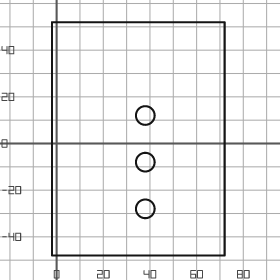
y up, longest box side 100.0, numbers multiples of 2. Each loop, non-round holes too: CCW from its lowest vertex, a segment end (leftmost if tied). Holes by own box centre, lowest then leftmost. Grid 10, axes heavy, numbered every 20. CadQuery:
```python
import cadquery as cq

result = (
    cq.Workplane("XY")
    .moveTo(-2.0, -48.0)
    .lineTo(72.0, -48.0)
    .lineTo(72.0, 52.0)
    .lineTo(-2.0, 52.0)
    .close()
    .moveTo(38.0, -28.0)
    .circle(4.0)
    .moveTo(38.0, -8.0)
    .circle(4.0)
    .moveTo(38.0, 12.0)
    .circle(4.0)
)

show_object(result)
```